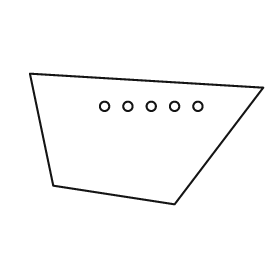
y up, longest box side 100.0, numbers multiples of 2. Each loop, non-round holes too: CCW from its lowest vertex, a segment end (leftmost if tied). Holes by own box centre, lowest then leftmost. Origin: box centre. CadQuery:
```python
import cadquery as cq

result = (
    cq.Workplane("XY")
    .moveTo(12.0, -28.0)
    .lineTo(50.0, 22.0)
    .lineTo(-50.0, 28.0)
    .lineTo(-40.0, -20.0)
    .close()
    .moveTo(-18.0, 14.0)
    .circle(2.0)
    .moveTo(-8.0, 14.0)
    .circle(2.0)
    .moveTo(2.0, 14.0)
    .circle(2.0)
    .moveTo(12.0, 14.0)
    .circle(2.0)
    .moveTo(22.0, 14.0)
    .circle(2.0)
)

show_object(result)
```